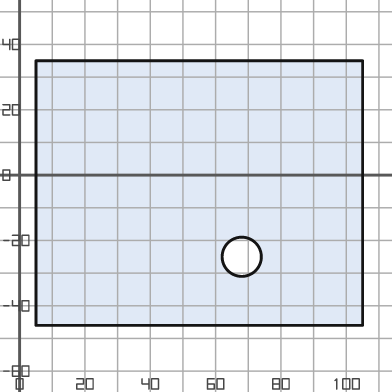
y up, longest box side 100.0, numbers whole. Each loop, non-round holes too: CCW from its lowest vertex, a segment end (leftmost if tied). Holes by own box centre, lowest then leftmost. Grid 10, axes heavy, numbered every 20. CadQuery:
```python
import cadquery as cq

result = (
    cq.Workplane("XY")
    .moveTo(5.0, -46.0)
    .lineTo(105.0, -46.0)
    .lineTo(105.0, 35.0)
    .lineTo(5.0, 35.0)
    .close()
    .moveTo(68.0, -25.0)
    .circle(6.0)
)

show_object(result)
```